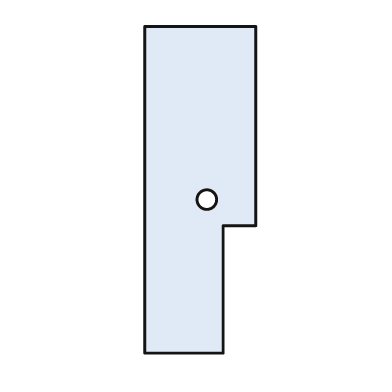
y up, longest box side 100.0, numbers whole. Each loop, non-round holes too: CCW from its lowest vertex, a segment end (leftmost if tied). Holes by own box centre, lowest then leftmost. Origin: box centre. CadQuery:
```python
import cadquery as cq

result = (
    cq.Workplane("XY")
    .moveTo(-17.0, -50.0)
    .lineTo(7.0, -50.0)
    .lineTo(7.0, -11.0)
    .lineTo(17.0, -11.0)
    .lineTo(17.0, 50.0)
    .lineTo(-17.0, 50.0)
    .close()
    .moveTo(2.0, -3.0)
    .circle(3.0)
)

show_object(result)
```